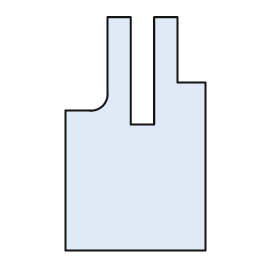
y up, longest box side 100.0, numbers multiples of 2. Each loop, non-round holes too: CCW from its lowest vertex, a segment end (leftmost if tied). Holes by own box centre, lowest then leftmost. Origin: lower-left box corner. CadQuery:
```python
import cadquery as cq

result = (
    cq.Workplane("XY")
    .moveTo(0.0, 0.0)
    .lineTo(60.0, 0.0)
    .lineTo(60.0, 72.0)
    .lineTo(48.0, 72.0)
    .lineTo(48.0, 100.0)
    .lineTo(38.0, 100.0)
    .lineTo(38.0, 54.0)
    .lineTo(28.0, 54.0)
    .lineTo(28.0, 100.0)
    .lineTo(18.0, 100.0)
    .lineTo(18.0, 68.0)
    .threePointArc((16.0, 62.0), (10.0, 60.0))
    .lineTo(0.0, 60.0)
    .close()
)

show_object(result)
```